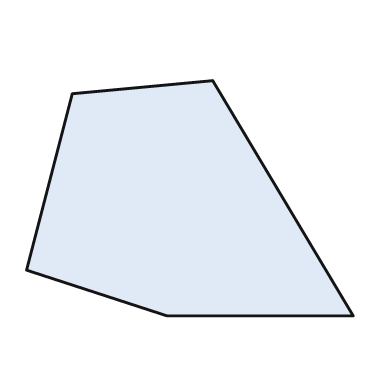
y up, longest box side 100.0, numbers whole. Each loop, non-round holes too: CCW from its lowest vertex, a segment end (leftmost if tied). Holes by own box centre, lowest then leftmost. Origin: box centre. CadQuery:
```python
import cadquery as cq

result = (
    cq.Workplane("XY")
    .moveTo(-7.0, -36.0)
    .lineTo(50.0, -36.0)
    .lineTo(7.0, 36.0)
    .lineTo(-36.0, 32.0)
    .lineTo(-50.0, -22.0)
    .close()
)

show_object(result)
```